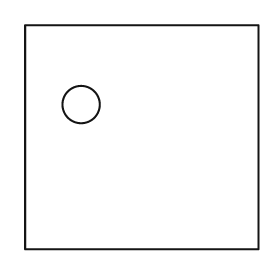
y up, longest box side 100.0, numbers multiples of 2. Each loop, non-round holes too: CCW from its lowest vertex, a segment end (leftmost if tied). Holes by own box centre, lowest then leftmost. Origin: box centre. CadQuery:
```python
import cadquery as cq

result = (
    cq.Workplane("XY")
    .moveTo(-50.0, -48.0)
    .lineTo(50.0, -48.0)
    .lineTo(50.0, 48.0)
    .lineTo(-50.0, 48.0)
    .close()
    .moveTo(-26.0, 14.0)
    .circle(8.0)
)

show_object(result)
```